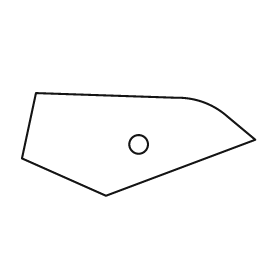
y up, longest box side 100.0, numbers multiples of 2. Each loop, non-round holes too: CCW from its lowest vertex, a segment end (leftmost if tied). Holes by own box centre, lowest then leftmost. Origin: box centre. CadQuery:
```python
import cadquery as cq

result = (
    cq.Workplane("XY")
    .moveTo(-14.0, -22.0)
    .lineTo(50.0, 2.0)
    .lineTo(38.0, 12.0)
    .threePointArc((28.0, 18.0), (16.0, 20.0))
    .lineTo(-44.0, 22.0)
    .lineTo(-50.0, -6.0)
    .close()
    .moveTo(0.0, 0.0)
    .circle(4.0)
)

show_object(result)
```